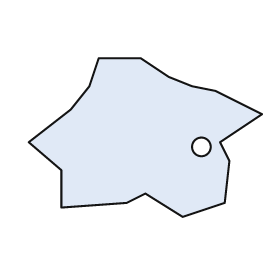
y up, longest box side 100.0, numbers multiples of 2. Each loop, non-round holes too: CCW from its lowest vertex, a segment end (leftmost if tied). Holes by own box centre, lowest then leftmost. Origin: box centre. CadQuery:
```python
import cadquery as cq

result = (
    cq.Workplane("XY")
    .moveTo(16.0, -34.0)
    .lineTo(34.0, -28.0)
    .lineTo(36.0, -10.0)
    .lineTo(32.0, -2.0)
    .lineTo(50.0, 10.0)
    .lineTo(30.0, 20.0)
    .lineTo(20.0, 22.0)
    .lineTo(10.0, 26.0)
    .lineTo(-2.0, 34.0)
    .lineTo(-20.0, 34.0)
    .lineTo(-24.0, 22.0)
    .lineTo(-32.0, 12.0)
    .lineTo(-50.0, -2.0)
    .lineTo(-36.0, -14.0)
    .lineTo(-36.0, -30.0)
    .lineTo(-8.0, -28.0)
    .lineTo(0.0, -24.0)
    .close()
    .moveTo(24.0, -4.0)
    .circle(4.0)
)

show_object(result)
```